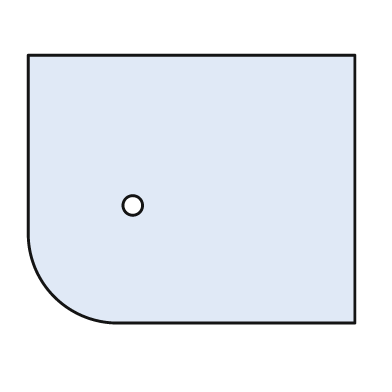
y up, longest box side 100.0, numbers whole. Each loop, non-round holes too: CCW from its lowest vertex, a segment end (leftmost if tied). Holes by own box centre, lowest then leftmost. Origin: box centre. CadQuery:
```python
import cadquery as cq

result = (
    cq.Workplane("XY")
    .moveTo(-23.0, -41.0)
    .lineTo(50.0, -41.0)
    .lineTo(50.0, 41.0)
    .lineTo(-50.0, 41.0)
    .lineTo(-50.0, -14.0)
    .threePointArc((-42.0, -33.0), (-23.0, -41.0))
    .close()
    .moveTo(-18.0, -5.0)
    .circle(3.0)
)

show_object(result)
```